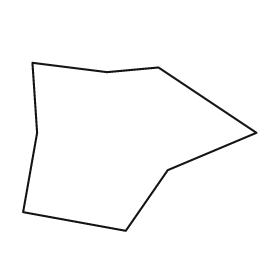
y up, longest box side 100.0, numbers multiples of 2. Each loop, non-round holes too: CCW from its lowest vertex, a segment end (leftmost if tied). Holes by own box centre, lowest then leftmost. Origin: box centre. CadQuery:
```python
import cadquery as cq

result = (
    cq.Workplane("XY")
    .moveTo(-6.0, -36.0)
    .lineTo(12.0, -10.0)
    .lineTo(50.0, 6.0)
    .lineTo(8.0, 34.0)
    .lineTo(-14.0, 32.0)
    .lineTo(-46.0, 36.0)
    .lineTo(-44.0, 6.0)
    .lineTo(-50.0, -28.0)
    .close()
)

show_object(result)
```